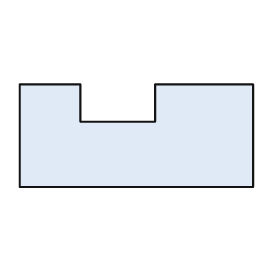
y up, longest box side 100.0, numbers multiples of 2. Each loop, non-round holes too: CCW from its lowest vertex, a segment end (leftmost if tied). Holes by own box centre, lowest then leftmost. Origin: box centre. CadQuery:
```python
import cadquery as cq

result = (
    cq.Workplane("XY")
    .moveTo(-50.0, -22.0)
    .lineTo(50.0, -22.0)
    .lineTo(50.0, 22.0)
    .lineTo(8.0, 22.0)
    .lineTo(8.0, 6.0)
    .lineTo(-24.0, 6.0)
    .lineTo(-24.0, 22.0)
    .lineTo(-50.0, 22.0)
    .close()
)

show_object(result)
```